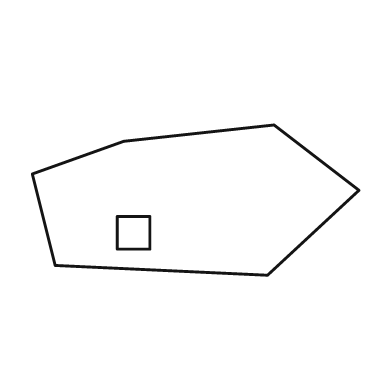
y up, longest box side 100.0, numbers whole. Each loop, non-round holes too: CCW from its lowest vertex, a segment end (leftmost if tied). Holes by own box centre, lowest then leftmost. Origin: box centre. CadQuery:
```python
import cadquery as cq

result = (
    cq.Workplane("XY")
    .moveTo(22.0, -23.0)
    .lineTo(50.0, 3.0)
    .lineTo(24.0, 23.0)
    .lineTo(-22.0, 18.0)
    .lineTo(-50.0, 8.0)
    .lineTo(-43.0, -20.0)
    .close()
    .moveTo(-24.0, -15.0)
    .lineTo(-14.0, -15.0)
    .lineTo(-14.0, -5.0)
    .lineTo(-24.0, -5.0)
    .close()
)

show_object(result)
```